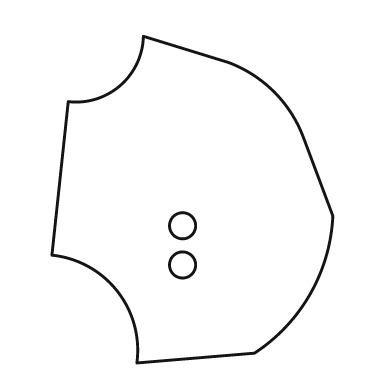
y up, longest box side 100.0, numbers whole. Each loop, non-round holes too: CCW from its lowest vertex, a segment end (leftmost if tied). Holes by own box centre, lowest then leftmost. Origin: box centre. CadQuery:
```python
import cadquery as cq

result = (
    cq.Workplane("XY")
    .moveTo(-17.0, -50.0)
    .lineTo(19.0, -47.0)
    .threePointArc((36.0, -29.0), (43.0, -5.0))
    .lineTo(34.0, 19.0)
    .threePointArc((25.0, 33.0), (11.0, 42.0))
    .lineTo(-15.0, 50.0)
    .threePointArc((-22.0, 35.0), (-38.0, 30.0))
    .lineTo(-43.0, -17.0)
    .threePointArc((-23.0, -28.0), (-17.0, -50.0))
    .close()
    .moveTo(-3.0, -20.0)
    .circle(4.0)
    .moveTo(-3.0, -8.0)
    .circle(4.0)
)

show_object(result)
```